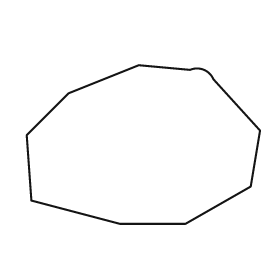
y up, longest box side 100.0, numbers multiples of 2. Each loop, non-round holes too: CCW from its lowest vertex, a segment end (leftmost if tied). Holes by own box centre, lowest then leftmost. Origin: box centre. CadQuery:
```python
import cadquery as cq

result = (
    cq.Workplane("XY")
    .moveTo(-10.0, -34.0)
    .lineTo(18.0, -34.0)
    .lineTo(46.0, -18.0)
    .lineTo(50.0, 6.0)
    .lineTo(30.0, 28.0)
    .threePointArc((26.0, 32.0), (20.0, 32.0))
    .lineTo(-2.0, 34.0)
    .lineTo(-32.0, 22.0)
    .lineTo(-50.0, 4.0)
    .lineTo(-48.0, -24.0)
    .close()
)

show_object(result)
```